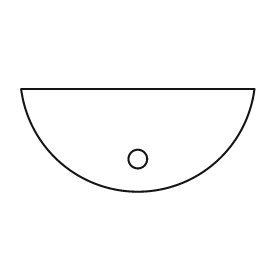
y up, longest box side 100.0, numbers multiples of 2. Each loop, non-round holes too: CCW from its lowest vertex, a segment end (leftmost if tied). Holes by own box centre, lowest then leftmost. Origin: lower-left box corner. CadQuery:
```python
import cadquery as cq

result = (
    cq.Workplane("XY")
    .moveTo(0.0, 44.0)
    .threePointArc((50.0, 0.0), (100.0, 44.0))
    .close()
    .moveTo(50.0, 14.0)
    .circle(4.0)
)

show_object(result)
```